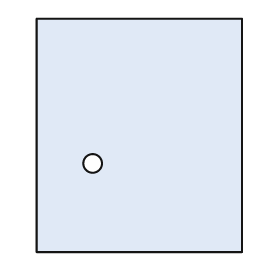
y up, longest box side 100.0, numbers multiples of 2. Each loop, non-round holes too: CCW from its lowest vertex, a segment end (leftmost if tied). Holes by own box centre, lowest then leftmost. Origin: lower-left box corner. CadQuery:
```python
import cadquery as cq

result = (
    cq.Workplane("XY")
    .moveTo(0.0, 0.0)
    .lineTo(88.0, 0.0)
    .lineTo(88.0, 100.0)
    .lineTo(0.0, 100.0)
    .close()
    .moveTo(24.0, 38.0)
    .circle(4.0)
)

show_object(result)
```